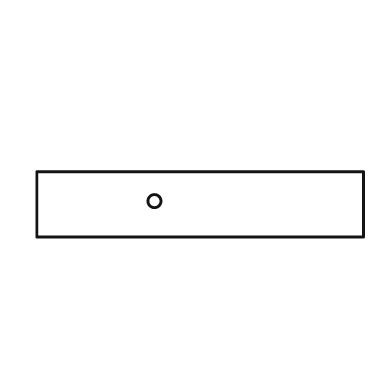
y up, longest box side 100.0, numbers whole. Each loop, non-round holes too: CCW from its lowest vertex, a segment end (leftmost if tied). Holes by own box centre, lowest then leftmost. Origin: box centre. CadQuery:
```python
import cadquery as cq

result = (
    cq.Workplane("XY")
    .moveTo(-50.0, -10.0)
    .lineTo(50.0, -10.0)
    .lineTo(50.0, 10.0)
    .lineTo(-50.0, 10.0)
    .close()
    .moveTo(-14.0, 1.0)
    .circle(2.0)
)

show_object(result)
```